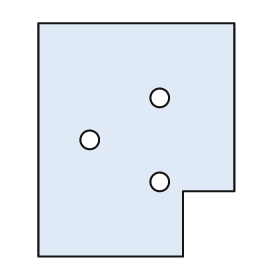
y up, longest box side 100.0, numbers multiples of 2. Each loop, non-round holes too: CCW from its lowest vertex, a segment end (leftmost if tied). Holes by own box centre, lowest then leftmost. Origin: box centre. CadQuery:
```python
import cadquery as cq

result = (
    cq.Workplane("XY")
    .moveTo(-42.0, -50.0)
    .lineTo(20.0, -50.0)
    .lineTo(20.0, -22.0)
    .lineTo(42.0, -22.0)
    .lineTo(42.0, 50.0)
    .lineTo(-42.0, 50.0)
    .close()
    .moveTo(10.0, -18.0)
    .circle(4.0)
    .moveTo(-20.0, 0.0)
    .circle(4.0)
    .moveTo(10.0, 18.0)
    .circle(4.0)
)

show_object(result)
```